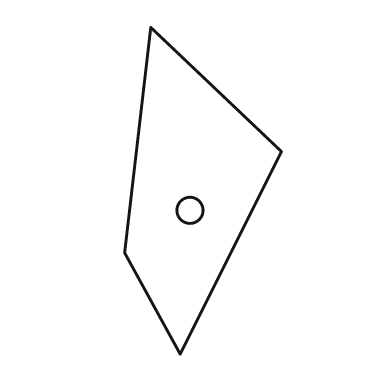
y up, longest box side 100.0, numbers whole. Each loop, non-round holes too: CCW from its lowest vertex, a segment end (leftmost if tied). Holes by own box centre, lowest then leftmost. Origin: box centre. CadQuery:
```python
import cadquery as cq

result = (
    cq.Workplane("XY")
    .moveTo(-7.0, -50.0)
    .lineTo(24.0, 12.0)
    .lineTo(-16.0, 50.0)
    .lineTo(-24.0, -19.0)
    .close()
    .moveTo(-4.0, -6.0)
    .circle(4.0)
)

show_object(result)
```